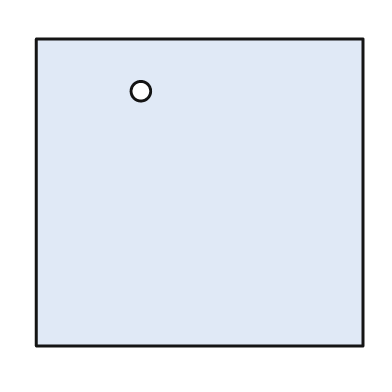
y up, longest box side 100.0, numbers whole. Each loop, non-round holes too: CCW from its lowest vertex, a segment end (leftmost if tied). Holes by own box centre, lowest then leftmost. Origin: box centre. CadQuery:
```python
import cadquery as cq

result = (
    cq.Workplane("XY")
    .moveTo(-50.0, -47.0)
    .lineTo(50.0, -47.0)
    .lineTo(50.0, 47.0)
    .lineTo(-50.0, 47.0)
    .close()
    .moveTo(-18.0, 31.0)
    .circle(3.0)
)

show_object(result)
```